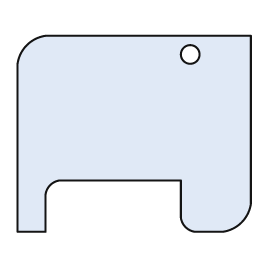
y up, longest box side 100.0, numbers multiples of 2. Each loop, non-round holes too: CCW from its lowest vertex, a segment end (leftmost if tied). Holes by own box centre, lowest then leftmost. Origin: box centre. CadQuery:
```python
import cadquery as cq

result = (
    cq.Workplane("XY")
    .moveTo(-50.0, -42.0)
    .lineTo(-38.0, -42.0)
    .lineTo(-38.0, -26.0)
    .threePointArc((-36.0, -22.0), (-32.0, -20.0))
    .lineTo(20.0, -20.0)
    .lineTo(20.0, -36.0)
    .threePointArc((22.0, -40.0), (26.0, -42.0))
    .lineTo(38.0, -42.0)
    .threePointArc((46.0, -38.0), (50.0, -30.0))
    .lineTo(50.0, 42.0)
    .lineTo(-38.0, 42.0)
    .threePointArc((-46.0, 38.0), (-50.0, 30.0))
    .close()
    .moveTo(24.0, 34.0)
    .circle(4.0)
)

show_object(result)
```